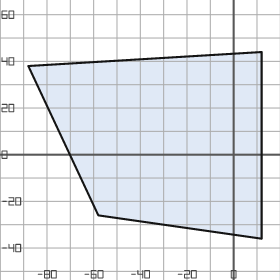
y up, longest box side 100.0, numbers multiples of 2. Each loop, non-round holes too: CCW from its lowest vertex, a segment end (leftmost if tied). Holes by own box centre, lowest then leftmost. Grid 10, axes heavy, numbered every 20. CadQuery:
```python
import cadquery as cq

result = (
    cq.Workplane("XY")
    .moveTo(12.0, -36.0)
    .lineTo(12.0, 44.0)
    .lineTo(-88.0, 38.0)
    .lineTo(-58.0, -26.0)
    .close()
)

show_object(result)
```